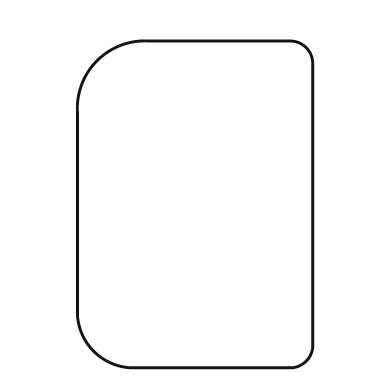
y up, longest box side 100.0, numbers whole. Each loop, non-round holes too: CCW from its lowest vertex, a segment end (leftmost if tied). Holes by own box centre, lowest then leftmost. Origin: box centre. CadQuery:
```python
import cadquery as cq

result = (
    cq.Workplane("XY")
    .moveTo(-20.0, -50.0)
    .lineTo(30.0, -50.0)
    .threePointArc((34.0, -48.0), (36.0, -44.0))
    .lineTo(36.0, 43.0)
    .threePointArc((34.0, 48.0), (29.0, 50.0))
    .lineTo(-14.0, 50.0)
    .threePointArc((-30.0, 44.0), (-36.0, 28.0))
    .lineTo(-36.0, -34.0)
    .threePointArc((-31.0, -45.0), (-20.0, -50.0))
    .close()
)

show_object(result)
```